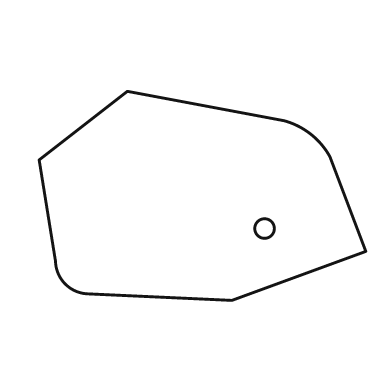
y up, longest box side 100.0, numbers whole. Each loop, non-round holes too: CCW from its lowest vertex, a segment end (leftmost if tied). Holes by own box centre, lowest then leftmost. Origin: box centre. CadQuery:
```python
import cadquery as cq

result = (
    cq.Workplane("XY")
    .moveTo(9.0, -32.0)
    .lineTo(50.0, -17.0)
    .lineTo(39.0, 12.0)
    .threePointArc((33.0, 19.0), (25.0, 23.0))
    .lineTo(-23.0, 32.0)
    .lineTo(-50.0, 11.0)
    .lineTo(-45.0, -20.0)
    .threePointArc((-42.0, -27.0), (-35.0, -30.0))
    .close()
    .moveTo(19.0, -10.0)
    .circle(3.0)
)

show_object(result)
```